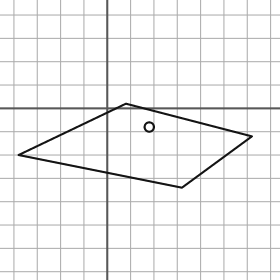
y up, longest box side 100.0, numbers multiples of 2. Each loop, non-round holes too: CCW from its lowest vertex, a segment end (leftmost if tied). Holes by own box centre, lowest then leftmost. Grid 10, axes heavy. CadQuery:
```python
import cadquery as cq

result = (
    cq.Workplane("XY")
    .moveTo(32.0, -34.0)
    .lineTo(62.0, -12.0)
    .lineTo(8.0, 2.0)
    .lineTo(-38.0, -20.0)
    .close()
    .moveTo(18.0, -8.0)
    .circle(2.0)
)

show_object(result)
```